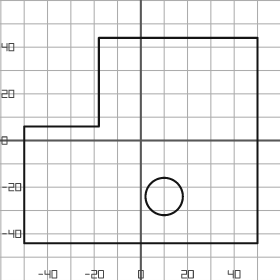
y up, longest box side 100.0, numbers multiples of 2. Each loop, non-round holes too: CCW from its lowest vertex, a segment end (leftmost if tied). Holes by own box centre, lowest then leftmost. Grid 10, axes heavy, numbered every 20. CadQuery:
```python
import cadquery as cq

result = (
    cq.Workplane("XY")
    .moveTo(-50.0, -44.0)
    .lineTo(50.0, -44.0)
    .lineTo(50.0, 44.0)
    .lineTo(-18.0, 44.0)
    .lineTo(-18.0, 6.0)
    .lineTo(-50.0, 6.0)
    .close()
    .moveTo(10.0, -24.0)
    .circle(8.0)
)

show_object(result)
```